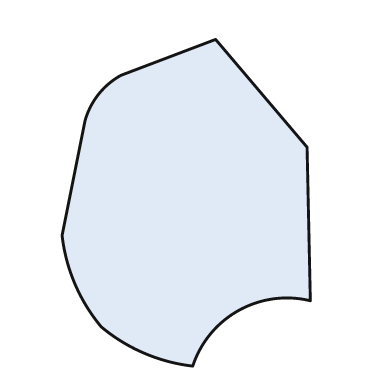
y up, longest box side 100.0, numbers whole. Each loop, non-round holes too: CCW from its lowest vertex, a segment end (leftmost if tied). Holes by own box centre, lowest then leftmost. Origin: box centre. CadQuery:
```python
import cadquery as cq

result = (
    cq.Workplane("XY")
    .moveTo(2.0, -50.0)
    .threePointArc((16.0, -33.0), (38.0, -30.0))
    .lineTo(37.0, 17.0)
    .lineTo(9.0, 50.0)
    .lineTo(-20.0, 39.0)
    .threePointArc((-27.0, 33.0), (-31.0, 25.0))
    .lineTo(-38.0, -10.0)
    .threePointArc((-34.0, -25.0), (-26.0, -38.0))
    .threePointArc((-13.0, -46.0), (2.0, -50.0))
    .close()
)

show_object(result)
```